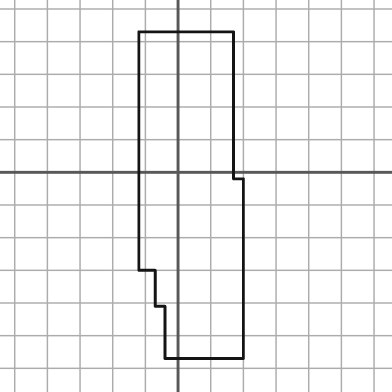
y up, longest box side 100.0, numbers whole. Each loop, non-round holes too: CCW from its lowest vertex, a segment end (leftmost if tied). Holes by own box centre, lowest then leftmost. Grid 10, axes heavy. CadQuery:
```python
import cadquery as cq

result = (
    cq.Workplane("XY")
    .moveTo(-4.0, -57.0)
    .lineTo(20.0, -57.0)
    .lineTo(20.0, -2.0)
    .lineTo(17.0, -2.0)
    .lineTo(17.0, 43.0)
    .lineTo(-12.0, 43.0)
    .lineTo(-12.0, -30.0)
    .lineTo(-7.0, -30.0)
    .lineTo(-7.0, -41.0)
    .lineTo(-4.0, -41.0)
    .close()
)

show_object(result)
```